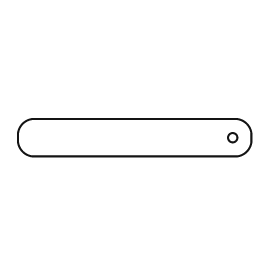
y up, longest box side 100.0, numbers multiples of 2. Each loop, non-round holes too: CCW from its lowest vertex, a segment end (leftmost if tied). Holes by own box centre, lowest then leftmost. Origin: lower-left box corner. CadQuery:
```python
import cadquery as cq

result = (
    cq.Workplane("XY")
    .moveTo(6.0, 0.0)
    .lineTo(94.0, 0.0)
    .threePointArc((98.0, 2.0), (100.0, 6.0))
    .lineTo(100.0, 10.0)
    .threePointArc((98.0, 14.0), (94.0, 16.0))
    .lineTo(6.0, 16.0)
    .threePointArc((2.0, 14.0), (0.0, 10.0))
    .lineTo(0.0, 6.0)
    .threePointArc((2.0, 2.0), (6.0, 0.0))
    .close()
    .moveTo(92.0, 8.0)
    .circle(2.0)
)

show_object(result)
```